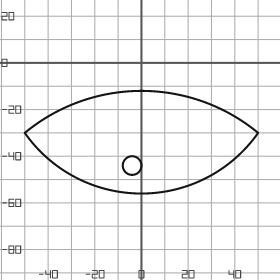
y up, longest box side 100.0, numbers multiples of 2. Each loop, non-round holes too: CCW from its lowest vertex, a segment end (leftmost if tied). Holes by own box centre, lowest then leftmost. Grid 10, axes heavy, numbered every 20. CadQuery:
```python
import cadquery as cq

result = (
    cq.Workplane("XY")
    .moveTo(-50.0, -30.0)
    .threePointArc((0.0, -56.0), (50.0, -30.0))
    .threePointArc((0.0, -12.0), (-50.0, -30.0))
    .close()
    .moveTo(-4.0, -44.0)
    .circle(4.0)
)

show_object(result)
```